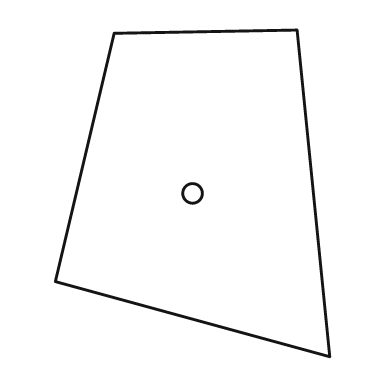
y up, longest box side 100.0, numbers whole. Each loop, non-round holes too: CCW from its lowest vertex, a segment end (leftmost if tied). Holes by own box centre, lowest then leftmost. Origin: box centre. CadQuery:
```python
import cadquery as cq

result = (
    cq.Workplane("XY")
    .moveTo(42.0, -50.0)
    .lineTo(32.0, 50.0)
    .lineTo(-24.0, 49.0)
    .lineTo(-42.0, -27.0)
    .close()
    .moveTo(0.0, 0.0)
    .circle(3.0)
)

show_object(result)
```